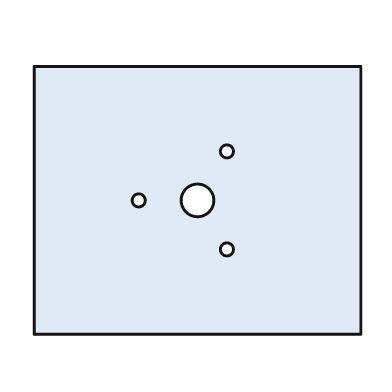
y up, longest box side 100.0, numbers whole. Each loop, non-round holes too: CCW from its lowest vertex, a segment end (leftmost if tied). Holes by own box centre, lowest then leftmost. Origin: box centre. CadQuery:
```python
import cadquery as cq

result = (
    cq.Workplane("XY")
    .moveTo(-50.0, -41.0)
    .lineTo(50.0, -41.0)
    .lineTo(50.0, 41.0)
    .lineTo(-50.0, 41.0)
    .close()
    .moveTo(9.0, -15.0)
    .circle(2.0)
    .moveTo(-18.0, 0.0)
    .circle(2.0)
    .moveTo(0.0, 0.0)
    .circle(5.0)
    .moveTo(9.0, 15.0)
    .circle(2.0)
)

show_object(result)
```